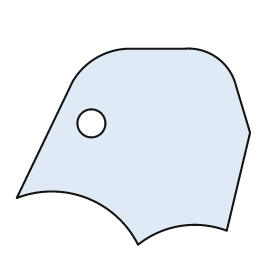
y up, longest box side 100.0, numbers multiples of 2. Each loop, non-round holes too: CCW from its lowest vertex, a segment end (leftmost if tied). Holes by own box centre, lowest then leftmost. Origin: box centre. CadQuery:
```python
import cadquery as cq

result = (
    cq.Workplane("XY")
    .moveTo(2.0, -42.0)
    .threePointArc((20.0, -34.0), (40.0, -36.0))
    .lineTo(50.0, 6.0)
    .lineTo(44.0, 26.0)
    .threePointArc((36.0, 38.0), (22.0, 42.0))
    .lineTo(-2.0, 42.0)
    .threePointArc((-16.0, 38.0), (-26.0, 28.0))
    .lineTo(-50.0, -22.0)
    .threePointArc((-20.0, -22.0), (2.0, -42.0))
    .close()
    .moveTo(-18.0, 10.0)
    .circle(6.0)
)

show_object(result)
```